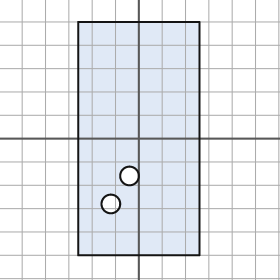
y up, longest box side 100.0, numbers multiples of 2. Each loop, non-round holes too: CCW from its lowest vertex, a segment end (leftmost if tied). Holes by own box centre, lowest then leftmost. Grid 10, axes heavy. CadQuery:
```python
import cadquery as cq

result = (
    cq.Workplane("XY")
    .moveTo(-26.0, -50.0)
    .lineTo(26.0, -50.0)
    .lineTo(26.0, 50.0)
    .lineTo(-26.0, 50.0)
    .close()
    .moveTo(-12.0, -28.0)
    .circle(4.0)
    .moveTo(-4.0, -16.0)
    .circle(4.0)
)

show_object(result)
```